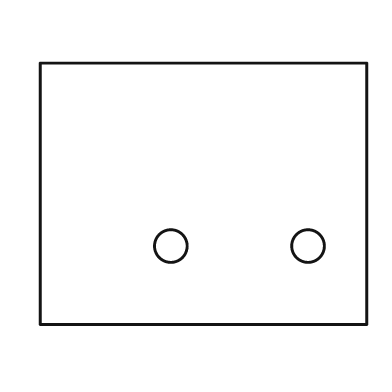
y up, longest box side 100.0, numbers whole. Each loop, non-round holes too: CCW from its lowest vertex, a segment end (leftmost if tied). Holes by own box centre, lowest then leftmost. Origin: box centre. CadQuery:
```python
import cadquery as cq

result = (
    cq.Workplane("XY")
    .moveTo(-50.0, -40.0)
    .lineTo(50.0, -40.0)
    .lineTo(50.0, 40.0)
    .lineTo(-50.0, 40.0)
    .close()
    .moveTo(-10.0, -16.0)
    .circle(5.0)
    .moveTo(32.0, -16.0)
    .circle(5.0)
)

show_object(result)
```